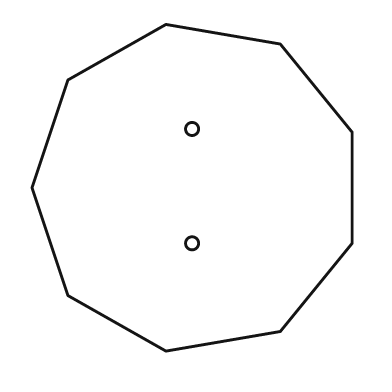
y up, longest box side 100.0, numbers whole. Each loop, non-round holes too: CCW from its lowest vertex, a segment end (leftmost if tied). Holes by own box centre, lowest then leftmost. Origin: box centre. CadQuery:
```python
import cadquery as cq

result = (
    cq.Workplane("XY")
    .moveTo(-8.0, -50.0)
    .lineTo(27.0, -44.0)
    .lineTo(49.0, -17.0)
    .lineTo(49.0, 17.0)
    .lineTo(27.0, 44.0)
    .lineTo(-8.0, 50.0)
    .lineTo(-38.0, 33.0)
    .lineTo(-49.0, 0.0)
    .lineTo(-38.0, -33.0)
    .close()
    .moveTo(0.0, -17.0)
    .circle(2.0)
    .moveTo(0.0, 18.0)
    .circle(2.0)
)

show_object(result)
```